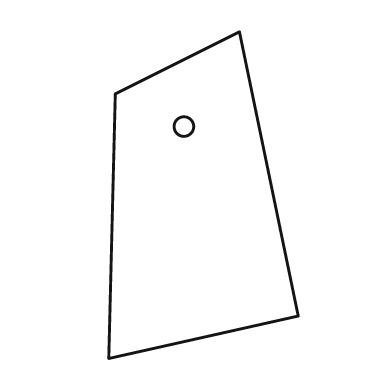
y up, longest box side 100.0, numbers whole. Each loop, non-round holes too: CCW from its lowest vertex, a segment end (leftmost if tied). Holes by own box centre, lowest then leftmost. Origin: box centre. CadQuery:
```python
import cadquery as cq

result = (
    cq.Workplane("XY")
    .moveTo(-29.0, -50.0)
    .lineTo(29.0, -37.0)
    .lineTo(11.0, 50.0)
    .lineTo(-27.0, 31.0)
    .close()
    .moveTo(-6.0, 21.0)
    .circle(3.0)
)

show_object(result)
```